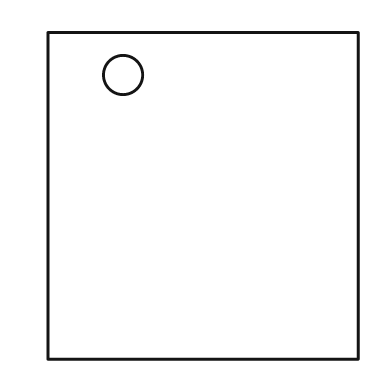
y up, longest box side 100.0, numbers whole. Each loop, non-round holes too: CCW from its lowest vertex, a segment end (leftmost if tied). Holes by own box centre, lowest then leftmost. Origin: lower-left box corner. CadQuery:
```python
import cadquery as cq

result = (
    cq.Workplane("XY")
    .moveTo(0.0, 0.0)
    .lineTo(95.0, 0.0)
    .lineTo(95.0, 100.0)
    .lineTo(0.0, 100.0)
    .close()
    .moveTo(23.0, 87.0)
    .circle(6.0)
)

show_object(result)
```